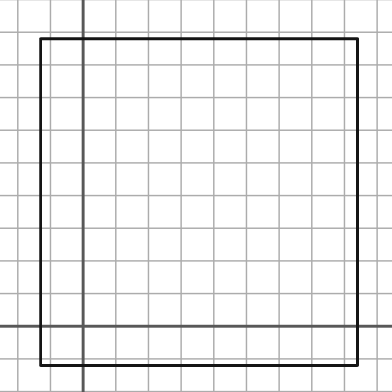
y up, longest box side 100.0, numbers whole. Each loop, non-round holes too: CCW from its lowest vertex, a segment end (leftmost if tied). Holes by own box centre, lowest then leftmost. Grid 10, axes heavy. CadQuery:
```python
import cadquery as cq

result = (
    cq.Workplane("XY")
    .moveTo(-13.0, -12.0)
    .lineTo(84.0, -12.0)
    .lineTo(84.0, 88.0)
    .lineTo(-13.0, 88.0)
    .close()
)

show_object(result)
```